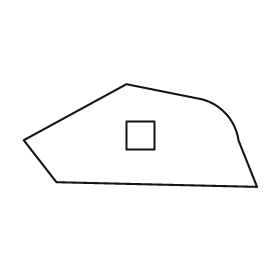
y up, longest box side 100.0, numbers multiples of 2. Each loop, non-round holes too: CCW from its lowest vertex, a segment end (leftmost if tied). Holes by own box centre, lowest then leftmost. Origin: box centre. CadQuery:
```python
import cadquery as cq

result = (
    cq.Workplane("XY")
    .moveTo(50.0, -22.0)
    .lineTo(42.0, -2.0)
    .threePointArc((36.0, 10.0), (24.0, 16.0))
    .lineTo(-6.0, 22.0)
    .lineTo(-50.0, -2.0)
    .lineTo(-36.0, -20.0)
    .close()
    .moveTo(-6.0, -6.0)
    .lineTo(6.0, -6.0)
    .lineTo(6.0, 6.0)
    .lineTo(-6.0, 6.0)
    .close()
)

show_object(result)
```